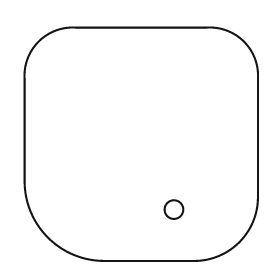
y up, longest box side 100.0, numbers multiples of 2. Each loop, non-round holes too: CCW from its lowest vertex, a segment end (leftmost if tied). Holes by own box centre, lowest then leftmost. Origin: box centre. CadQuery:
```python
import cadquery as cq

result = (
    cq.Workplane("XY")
    .moveTo(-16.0, -50.0)
    .lineTo(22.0, -50.0)
    .threePointArc((42.0, -42.0), (50.0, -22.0))
    .lineTo(50.0, 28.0)
    .threePointArc((44.0, 44.0), (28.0, 50.0))
    .lineTo(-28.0, 50.0)
    .threePointArc((-44.0, 44.0), (-50.0, 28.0))
    .lineTo(-50.0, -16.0)
    .threePointArc((-40.0, -40.0), (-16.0, -50.0))
    .close()
    .moveTo(14.0, -28.0)
    .circle(4.0)
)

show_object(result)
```